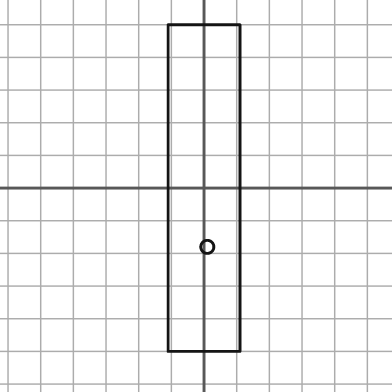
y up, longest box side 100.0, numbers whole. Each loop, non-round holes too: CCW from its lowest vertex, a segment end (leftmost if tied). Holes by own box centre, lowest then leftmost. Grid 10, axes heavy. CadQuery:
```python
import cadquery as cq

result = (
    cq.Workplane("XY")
    .moveTo(-11.0, -50.0)
    .lineTo(11.0, -50.0)
    .lineTo(11.0, 50.0)
    .lineTo(-11.0, 50.0)
    .close()
    .moveTo(1.0, -18.0)
    .circle(2.0)
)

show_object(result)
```